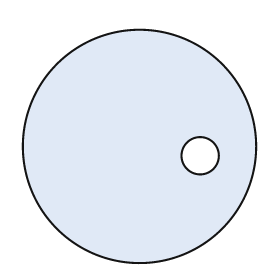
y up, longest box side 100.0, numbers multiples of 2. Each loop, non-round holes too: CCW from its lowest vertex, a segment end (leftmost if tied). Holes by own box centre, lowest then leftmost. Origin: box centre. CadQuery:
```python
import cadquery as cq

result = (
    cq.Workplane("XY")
    .moveTo(0.0, 0.0)
    .circle(50.0)
    .moveTo(26.0, -4.0)
    .circle(8.0)
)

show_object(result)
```